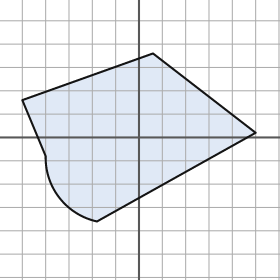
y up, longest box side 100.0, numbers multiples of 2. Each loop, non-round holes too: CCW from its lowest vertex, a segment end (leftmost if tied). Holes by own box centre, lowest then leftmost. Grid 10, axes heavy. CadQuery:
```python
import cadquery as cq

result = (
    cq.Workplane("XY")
    .moveTo(-18.0, -36.0)
    .lineTo(50.0, 2.0)
    .lineTo(6.0, 36.0)
    .lineTo(-50.0, 16.0)
    .lineTo(-40.0, -8.0)
    .threePointArc((-34.0, -26.0), (-18.0, -36.0))
    .close()
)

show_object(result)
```